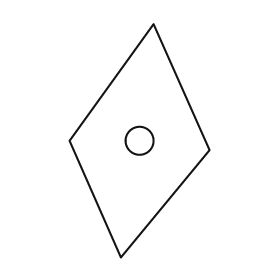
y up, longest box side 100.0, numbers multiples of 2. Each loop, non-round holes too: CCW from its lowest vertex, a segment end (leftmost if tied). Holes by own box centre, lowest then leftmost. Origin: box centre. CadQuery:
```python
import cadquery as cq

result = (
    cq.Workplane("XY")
    .moveTo(-8.0, -50.0)
    .lineTo(30.0, -4.0)
    .lineTo(6.0, 50.0)
    .lineTo(-30.0, 0.0)
    .close()
    .moveTo(0.0, 0.0)
    .circle(6.0)
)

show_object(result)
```